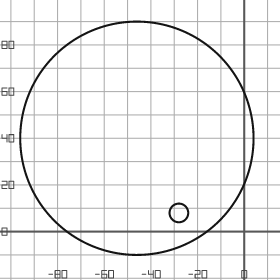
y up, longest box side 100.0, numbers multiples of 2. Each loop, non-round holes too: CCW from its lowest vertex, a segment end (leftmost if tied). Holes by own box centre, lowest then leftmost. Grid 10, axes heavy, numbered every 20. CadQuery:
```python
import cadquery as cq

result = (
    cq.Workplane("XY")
    .moveTo(-46.0, 40.0)
    .circle(50.0)
    .moveTo(-28.0, 8.0)
    .circle(4.0)
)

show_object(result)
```